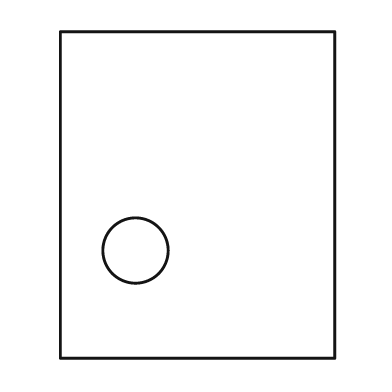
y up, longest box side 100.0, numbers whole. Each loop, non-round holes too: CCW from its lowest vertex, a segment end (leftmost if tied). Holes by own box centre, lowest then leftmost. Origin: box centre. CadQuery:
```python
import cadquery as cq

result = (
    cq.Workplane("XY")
    .moveTo(-42.0, -50.0)
    .lineTo(42.0, -50.0)
    .lineTo(42.0, 50.0)
    .lineTo(-42.0, 50.0)
    .close()
    .moveTo(-19.0, -17.0)
    .circle(10.0)
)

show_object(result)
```